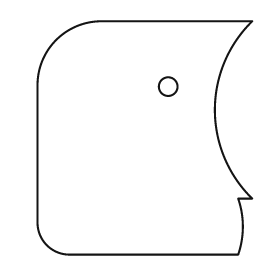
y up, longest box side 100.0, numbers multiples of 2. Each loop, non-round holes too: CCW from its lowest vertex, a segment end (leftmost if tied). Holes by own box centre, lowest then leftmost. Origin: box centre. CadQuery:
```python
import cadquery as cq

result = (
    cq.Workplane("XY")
    .moveTo(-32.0, -50.0)
    .lineTo(40.0, -50.0)
    .threePointArc((42.0, -38.0), (40.0, -26.0))
    .lineTo(46.0, -26.0)
    .threePointArc((30.0, 12.0), (46.0, 50.0))
    .lineTo(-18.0, 50.0)
    .threePointArc((-38.0, 42.0), (-46.0, 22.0))
    .lineTo(-46.0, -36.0)
    .threePointArc((-42.0, -46.0), (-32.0, -50.0))
    .close()
    .moveTo(10.0, 22.0)
    .circle(4.0)
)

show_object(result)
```